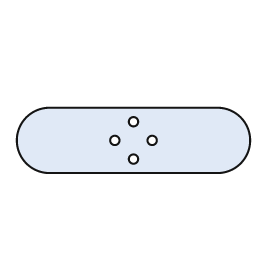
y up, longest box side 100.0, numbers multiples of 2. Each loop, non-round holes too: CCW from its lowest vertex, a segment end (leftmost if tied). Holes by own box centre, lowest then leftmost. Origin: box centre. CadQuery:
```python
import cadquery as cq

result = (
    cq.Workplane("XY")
    .moveTo(-36.0, -14.0)
    .lineTo(36.0, -14.0)
    .threePointArc((50.0, 0.0), (36.0, 14.0))
    .lineTo(-36.0, 14.0)
    .threePointArc((-50.0, 0.0), (-36.0, -14.0))
    .close()
    .moveTo(0.0, -8.0)
    .circle(2.0)
    .moveTo(-8.0, 0.0)
    .circle(2.0)
    .moveTo(8.0, 0.0)
    .circle(2.0)
    .moveTo(0.0, 8.0)
    .circle(2.0)
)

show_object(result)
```